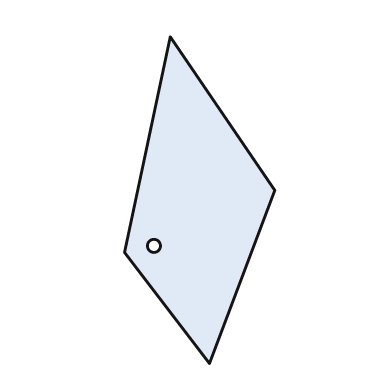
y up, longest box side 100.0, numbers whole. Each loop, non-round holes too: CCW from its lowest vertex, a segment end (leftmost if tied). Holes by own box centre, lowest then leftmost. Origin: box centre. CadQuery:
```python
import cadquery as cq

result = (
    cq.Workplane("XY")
    .moveTo(3.0, -50.0)
    .lineTo(23.0, 3.0)
    .lineTo(-9.0, 50.0)
    .lineTo(-23.0, -16.0)
    .close()
    .moveTo(-14.0, -14.0)
    .circle(2.0)
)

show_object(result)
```